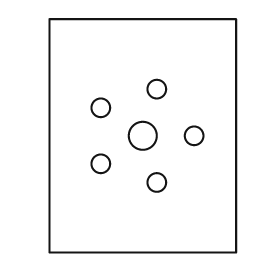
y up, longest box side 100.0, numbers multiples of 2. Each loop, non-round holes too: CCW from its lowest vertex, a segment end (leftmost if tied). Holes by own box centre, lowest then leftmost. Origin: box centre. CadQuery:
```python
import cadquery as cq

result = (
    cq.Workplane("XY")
    .moveTo(-40.0, -50.0)
    .lineTo(40.0, -50.0)
    .lineTo(40.0, 50.0)
    .lineTo(-40.0, 50.0)
    .close()
    .moveTo(6.0, -20.0)
    .circle(4.0)
    .moveTo(-18.0, -12.0)
    .circle(4.0)
    .moveTo(0.0, 0.0)
    .circle(6.0)
    .moveTo(22.0, 0.0)
    .circle(4.0)
    .moveTo(-18.0, 12.0)
    .circle(4.0)
    .moveTo(6.0, 20.0)
    .circle(4.0)
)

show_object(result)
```